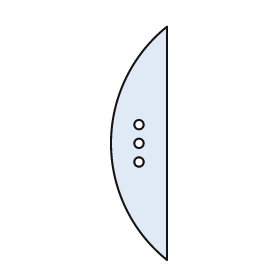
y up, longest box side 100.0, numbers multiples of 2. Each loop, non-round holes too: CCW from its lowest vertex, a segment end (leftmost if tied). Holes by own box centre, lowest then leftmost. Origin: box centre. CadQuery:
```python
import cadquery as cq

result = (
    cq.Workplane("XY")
    .moveTo(12.0, -50.0)
    .lineTo(12.0, 50.0)
    .threePointArc((-12.0, 0.0), (12.0, -50.0))
    .close()
    .moveTo(0.0, -8.0)
    .circle(2.0)
    .moveTo(0.0, 0.0)
    .circle(2.0)
    .moveTo(0.0, 8.0)
    .circle(2.0)
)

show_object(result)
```